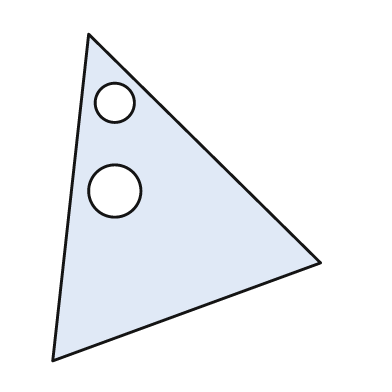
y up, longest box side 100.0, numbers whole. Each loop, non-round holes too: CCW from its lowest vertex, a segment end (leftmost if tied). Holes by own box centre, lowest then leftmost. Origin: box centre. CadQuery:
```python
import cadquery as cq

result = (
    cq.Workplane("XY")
    .moveTo(-41.0, -50.0)
    .lineTo(41.0, -20.0)
    .lineTo(-30.0, 50.0)
    .close()
    .moveTo(-22.0, 2.0)
    .circle(8.0)
    .moveTo(-22.0, 29.0)
    .circle(6.0)
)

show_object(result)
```